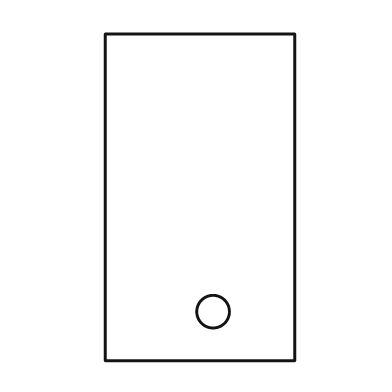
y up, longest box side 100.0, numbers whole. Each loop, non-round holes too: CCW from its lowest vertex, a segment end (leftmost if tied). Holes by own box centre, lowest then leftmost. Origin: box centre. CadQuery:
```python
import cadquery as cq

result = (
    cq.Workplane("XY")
    .moveTo(-29.0, -50.0)
    .lineTo(29.0, -50.0)
    .lineTo(29.0, 50.0)
    .lineTo(-29.0, 50.0)
    .close()
    .moveTo(4.0, -35.0)
    .circle(5.0)
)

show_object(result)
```